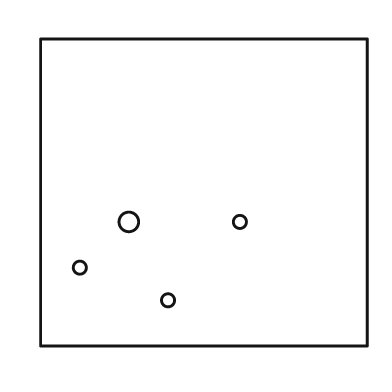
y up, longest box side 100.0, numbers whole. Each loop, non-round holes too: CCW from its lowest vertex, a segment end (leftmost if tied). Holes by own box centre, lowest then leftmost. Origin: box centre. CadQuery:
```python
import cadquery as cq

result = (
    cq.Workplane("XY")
    .moveTo(-50.0, -47.0)
    .lineTo(50.0, -47.0)
    .lineTo(50.0, 47.0)
    .lineTo(-50.0, 47.0)
    .close()
    .moveTo(-11.0, -33.0)
    .circle(2.0)
    .moveTo(-38.0, -23.0)
    .circle(2.0)
    .moveTo(-23.0, -9.0)
    .circle(3.0)
    .moveTo(11.0, -9.0)
    .circle(2.0)
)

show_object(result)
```